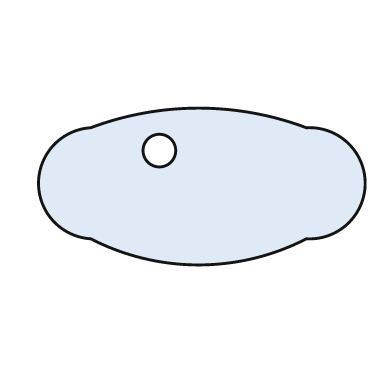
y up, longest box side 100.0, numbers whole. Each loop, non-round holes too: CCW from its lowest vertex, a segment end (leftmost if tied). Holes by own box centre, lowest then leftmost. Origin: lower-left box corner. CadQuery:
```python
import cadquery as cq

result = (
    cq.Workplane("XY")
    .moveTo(16.0, 8.0)
    .threePointArc((49.0, 0.0), (82.0, 8.0))
    .threePointArc((100.0, 25.0), (82.0, 42.0))
    .threePointArc((49.0, 48.0), (16.0, 42.0))
    .threePointArc((0.0, 25.0), (16.0, 8.0))
    .close()
    .moveTo(37.0, 35.0)
    .circle(5.0)
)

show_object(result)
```